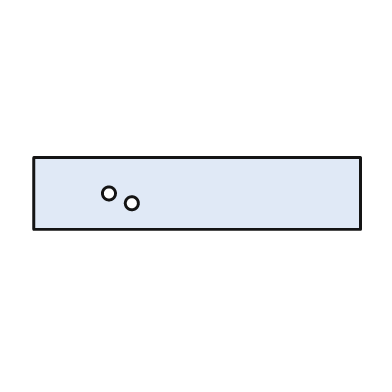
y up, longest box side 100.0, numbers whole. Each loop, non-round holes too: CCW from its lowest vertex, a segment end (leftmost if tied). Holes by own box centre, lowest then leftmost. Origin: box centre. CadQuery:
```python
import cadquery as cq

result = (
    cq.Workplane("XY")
    .moveTo(-50.0, -11.0)
    .lineTo(50.0, -11.0)
    .lineTo(50.0, 11.0)
    .lineTo(-50.0, 11.0)
    .close()
    .moveTo(-20.0, -3.0)
    .circle(2.0)
    .moveTo(-27.0, 0.0)
    .circle(2.0)
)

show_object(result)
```